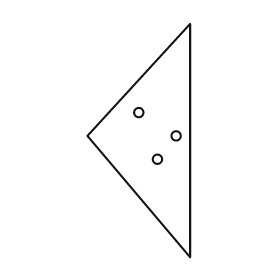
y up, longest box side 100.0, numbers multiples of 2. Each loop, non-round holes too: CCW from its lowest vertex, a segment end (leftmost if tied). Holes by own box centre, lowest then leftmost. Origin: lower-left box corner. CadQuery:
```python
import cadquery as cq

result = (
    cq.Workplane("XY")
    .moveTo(44.0, 0.0)
    .lineTo(44.0, 100.0)
    .lineTo(0.0, 52.0)
    .close()
    .moveTo(30.0, 42.0)
    .circle(2.0)
    .moveTo(38.0, 52.0)
    .circle(2.0)
    .moveTo(22.0, 62.0)
    .circle(2.0)
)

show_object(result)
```